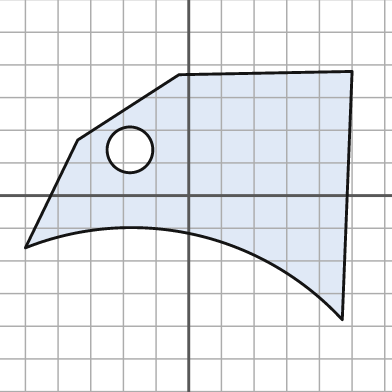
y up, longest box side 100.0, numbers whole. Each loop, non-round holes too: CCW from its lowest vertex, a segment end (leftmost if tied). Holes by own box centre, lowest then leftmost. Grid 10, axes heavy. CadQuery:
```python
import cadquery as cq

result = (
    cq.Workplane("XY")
    .moveTo(47.0, -38.0)
    .lineTo(50.0, 38.0)
    .lineTo(-3.0, 37.0)
    .lineTo(-34.0, 17.0)
    .lineTo(-50.0, -16.0)
    .threePointArc((2.0, -12.0), (47.0, -38.0))
    .close()
    .moveTo(-18.0, 14.0)
    .circle(7.0)
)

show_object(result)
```